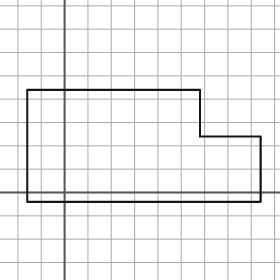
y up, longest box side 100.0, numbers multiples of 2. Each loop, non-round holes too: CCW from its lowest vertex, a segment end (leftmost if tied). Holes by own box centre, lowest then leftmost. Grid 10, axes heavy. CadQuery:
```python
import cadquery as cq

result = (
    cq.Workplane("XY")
    .moveTo(-16.0, -4.0)
    .lineTo(84.0, -4.0)
    .lineTo(84.0, 24.0)
    .lineTo(58.0, 24.0)
    .lineTo(58.0, 44.0)
    .lineTo(-16.0, 44.0)
    .close()
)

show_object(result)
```